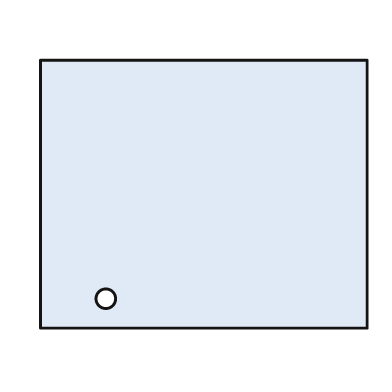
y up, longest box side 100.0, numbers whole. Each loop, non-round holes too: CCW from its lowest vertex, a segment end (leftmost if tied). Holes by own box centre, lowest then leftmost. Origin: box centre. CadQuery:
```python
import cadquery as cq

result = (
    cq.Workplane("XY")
    .moveTo(-50.0, -41.0)
    .lineTo(50.0, -41.0)
    .lineTo(50.0, 41.0)
    .lineTo(-50.0, 41.0)
    .close()
    .moveTo(-30.0, -32.0)
    .circle(3.0)
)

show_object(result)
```